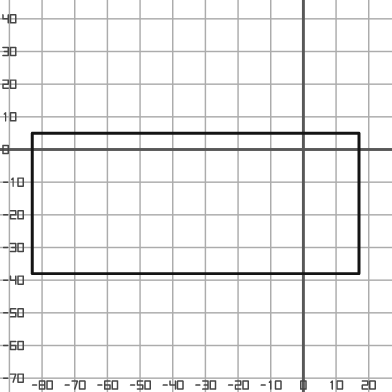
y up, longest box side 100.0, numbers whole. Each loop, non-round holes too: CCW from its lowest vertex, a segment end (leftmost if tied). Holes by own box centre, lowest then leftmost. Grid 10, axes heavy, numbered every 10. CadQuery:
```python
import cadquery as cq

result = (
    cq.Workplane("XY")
    .moveTo(-83.0, -38.0)
    .lineTo(17.0, -38.0)
    .lineTo(17.0, 5.0)
    .lineTo(-83.0, 5.0)
    .close()
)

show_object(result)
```